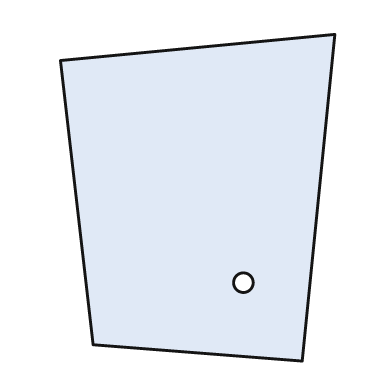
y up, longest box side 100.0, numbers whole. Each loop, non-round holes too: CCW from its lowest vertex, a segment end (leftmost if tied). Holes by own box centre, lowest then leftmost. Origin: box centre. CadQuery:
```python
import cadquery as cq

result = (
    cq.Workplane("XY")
    .moveTo(32.0, -50.0)
    .lineTo(42.0, 50.0)
    .lineTo(-42.0, 42.0)
    .lineTo(-32.0, -45.0)
    .close()
    .moveTo(14.0, -26.0)
    .circle(3.0)
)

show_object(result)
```